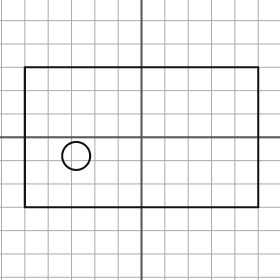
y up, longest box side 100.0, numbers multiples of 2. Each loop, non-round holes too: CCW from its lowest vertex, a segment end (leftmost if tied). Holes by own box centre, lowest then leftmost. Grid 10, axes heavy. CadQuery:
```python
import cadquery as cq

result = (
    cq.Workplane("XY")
    .moveTo(-50.0, -30.0)
    .lineTo(50.0, -30.0)
    .lineTo(50.0, 30.0)
    .lineTo(-50.0, 30.0)
    .close()
    .moveTo(-28.0, -8.0)
    .circle(6.0)
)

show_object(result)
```